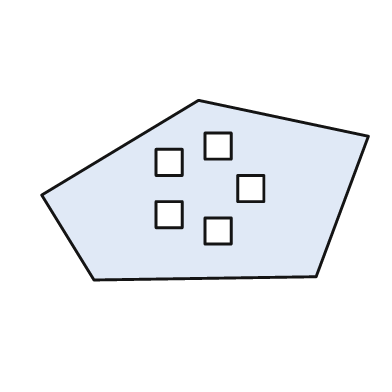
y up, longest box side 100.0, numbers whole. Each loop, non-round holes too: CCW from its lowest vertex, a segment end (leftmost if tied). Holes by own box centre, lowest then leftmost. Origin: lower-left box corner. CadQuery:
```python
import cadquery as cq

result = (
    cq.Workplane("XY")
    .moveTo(16.0, 0.0)
    .lineTo(84.0, 1.0)
    .lineTo(100.0, 44.0)
    .lineTo(48.0, 55.0)
    .lineTo(0.0, 26.0)
    .close()
    .moveTo(50.0, 11.0)
    .lineTo(58.0, 11.0)
    .lineTo(58.0, 19.0)
    .lineTo(50.0, 19.0)
    .close()
    .moveTo(35.0, 16.0)
    .lineTo(43.0, 16.0)
    .lineTo(43.0, 24.0)
    .lineTo(35.0, 24.0)
    .close()
    .moveTo(60.0, 24.0)
    .lineTo(68.0, 24.0)
    .lineTo(68.0, 32.0)
    .lineTo(60.0, 32.0)
    .close()
    .moveTo(35.0, 32.0)
    .lineTo(43.0, 32.0)
    .lineTo(43.0, 40.0)
    .lineTo(35.0, 40.0)
    .close()
    .moveTo(50.0, 37.0)
    .lineTo(58.0, 37.0)
    .lineTo(58.0, 45.0)
    .lineTo(50.0, 45.0)
    .close()
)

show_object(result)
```